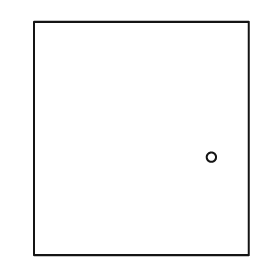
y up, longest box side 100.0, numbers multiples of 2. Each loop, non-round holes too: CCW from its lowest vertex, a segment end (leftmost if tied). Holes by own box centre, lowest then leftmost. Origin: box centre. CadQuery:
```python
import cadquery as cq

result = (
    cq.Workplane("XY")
    .moveTo(-46.0, -50.0)
    .lineTo(46.0, -50.0)
    .lineTo(46.0, 50.0)
    .lineTo(-46.0, 50.0)
    .close()
    .moveTo(30.0, -8.0)
    .circle(2.0)
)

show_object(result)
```